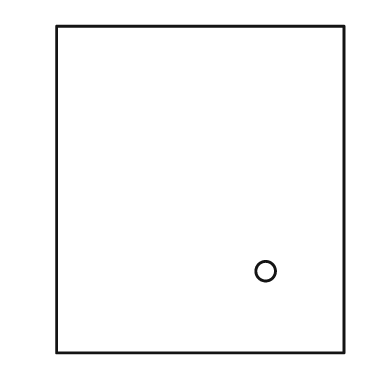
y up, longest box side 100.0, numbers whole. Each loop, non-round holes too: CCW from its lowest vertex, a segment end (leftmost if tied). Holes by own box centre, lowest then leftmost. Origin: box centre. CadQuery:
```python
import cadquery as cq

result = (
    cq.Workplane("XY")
    .moveTo(-44.0, -50.0)
    .lineTo(44.0, -50.0)
    .lineTo(44.0, 50.0)
    .lineTo(-44.0, 50.0)
    .close()
    .moveTo(20.0, -25.0)
    .circle(3.0)
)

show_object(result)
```